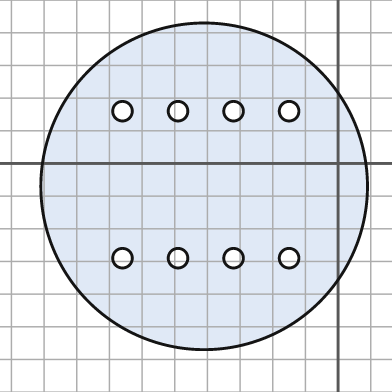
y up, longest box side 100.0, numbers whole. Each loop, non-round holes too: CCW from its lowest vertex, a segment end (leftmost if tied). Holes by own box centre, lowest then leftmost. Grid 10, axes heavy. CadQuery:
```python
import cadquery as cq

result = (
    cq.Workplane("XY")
    .moveTo(-41.0, -7.0)
    .circle(50.0)
    .moveTo(-66.0, -29.0)
    .circle(3.0)
    .moveTo(-49.0, -29.0)
    .circle(3.0)
    .moveTo(-32.0, -29.0)
    .circle(3.0)
    .moveTo(-15.0, -29.0)
    .circle(3.0)
    .moveTo(-66.0, 16.0)
    .circle(3.0)
    .moveTo(-49.0, 16.0)
    .circle(3.0)
    .moveTo(-32.0, 16.0)
    .circle(3.0)
    .moveTo(-15.0, 16.0)
    .circle(3.0)
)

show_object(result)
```